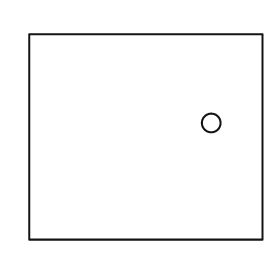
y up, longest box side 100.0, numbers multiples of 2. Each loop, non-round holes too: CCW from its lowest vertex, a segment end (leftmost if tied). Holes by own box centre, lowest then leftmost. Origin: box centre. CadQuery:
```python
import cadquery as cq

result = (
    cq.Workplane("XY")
    .moveTo(-50.0, -44.0)
    .lineTo(50.0, -44.0)
    .lineTo(50.0, 44.0)
    .lineTo(-50.0, 44.0)
    .close()
    .moveTo(28.0, 6.0)
    .circle(4.0)
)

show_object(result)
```